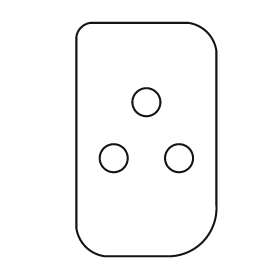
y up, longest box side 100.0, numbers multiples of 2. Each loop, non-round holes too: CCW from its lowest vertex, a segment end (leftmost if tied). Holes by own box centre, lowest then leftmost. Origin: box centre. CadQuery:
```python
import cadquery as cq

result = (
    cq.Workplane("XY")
    .moveTo(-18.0, -50.0)
    .lineTo(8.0, -50.0)
    .threePointArc((24.0, -44.0), (30.0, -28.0))
    .lineTo(30.0, 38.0)
    .threePointArc((26.0, 46.0), (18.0, 50.0))
    .lineTo(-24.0, 50.0)
    .threePointArc((-28.0, 48.0), (-30.0, 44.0))
    .lineTo(-30.0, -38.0)
    .threePointArc((-26.0, -46.0), (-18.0, -50.0))
    .close()
    .moveTo(-14.0, -8.0)
    .circle(6.0)
    .moveTo(14.0, -8.0)
    .circle(6.0)
    .moveTo(0.0, 16.0)
    .circle(6.0)
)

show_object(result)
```